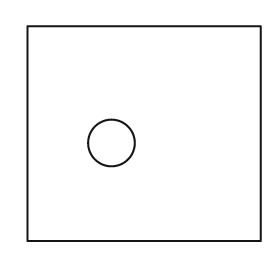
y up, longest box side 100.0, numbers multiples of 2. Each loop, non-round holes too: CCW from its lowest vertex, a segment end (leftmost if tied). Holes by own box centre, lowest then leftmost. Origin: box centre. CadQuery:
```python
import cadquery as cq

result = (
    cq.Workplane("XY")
    .moveTo(-50.0, -46.0)
    .lineTo(50.0, -46.0)
    .lineTo(50.0, 46.0)
    .lineTo(-50.0, 46.0)
    .close()
    .moveTo(-14.0, -4.0)
    .circle(10.0)
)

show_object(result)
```